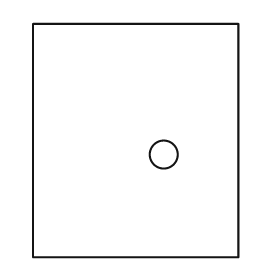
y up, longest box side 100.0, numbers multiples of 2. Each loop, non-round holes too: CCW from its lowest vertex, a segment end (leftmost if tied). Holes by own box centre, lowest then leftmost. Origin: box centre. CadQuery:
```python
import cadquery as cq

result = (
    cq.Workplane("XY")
    .moveTo(-44.0, -50.0)
    .lineTo(44.0, -50.0)
    .lineTo(44.0, 50.0)
    .lineTo(-44.0, 50.0)
    .close()
    .moveTo(12.0, -6.0)
    .circle(6.0)
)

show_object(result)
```